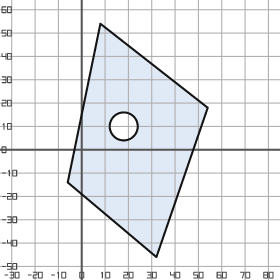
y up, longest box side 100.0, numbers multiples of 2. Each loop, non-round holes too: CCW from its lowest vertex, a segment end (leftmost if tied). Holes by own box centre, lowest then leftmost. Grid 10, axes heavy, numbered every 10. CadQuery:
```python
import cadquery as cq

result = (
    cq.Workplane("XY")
    .moveTo(32.0, -46.0)
    .lineTo(54.0, 18.0)
    .lineTo(8.0, 54.0)
    .lineTo(-6.0, -14.0)
    .close()
    .moveTo(18.0, 10.0)
    .circle(6.0)
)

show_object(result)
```